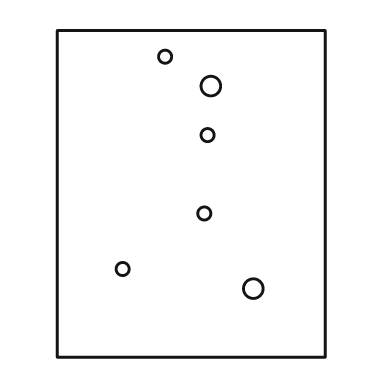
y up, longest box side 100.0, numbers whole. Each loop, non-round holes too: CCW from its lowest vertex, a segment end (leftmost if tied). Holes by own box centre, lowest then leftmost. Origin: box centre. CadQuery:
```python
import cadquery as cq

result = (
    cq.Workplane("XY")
    .moveTo(-41.0, -50.0)
    .lineTo(41.0, -50.0)
    .lineTo(41.0, 50.0)
    .lineTo(-41.0, 50.0)
    .close()
    .moveTo(19.0, -29.0)
    .circle(3.0)
    .moveTo(-21.0, -23.0)
    .circle(2.0)
    .moveTo(4.0, -6.0)
    .circle(2.0)
    .moveTo(5.0, 18.0)
    .circle(2.0)
    .moveTo(6.0, 33.0)
    .circle(3.0)
    .moveTo(-8.0, 42.0)
    .circle(2.0)
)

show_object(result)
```